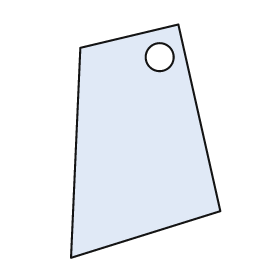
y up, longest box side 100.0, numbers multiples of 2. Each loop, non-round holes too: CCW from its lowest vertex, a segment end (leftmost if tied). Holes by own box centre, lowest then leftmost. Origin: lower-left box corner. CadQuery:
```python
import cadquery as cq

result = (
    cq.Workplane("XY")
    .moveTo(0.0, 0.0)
    .lineTo(64.0, 20.0)
    .lineTo(46.0, 100.0)
    .lineTo(4.0, 90.0)
    .close()
    .moveTo(38.0, 86.0)
    .circle(6.0)
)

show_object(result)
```